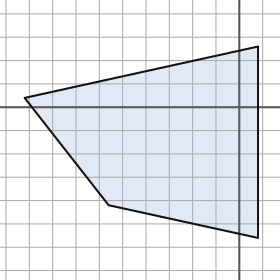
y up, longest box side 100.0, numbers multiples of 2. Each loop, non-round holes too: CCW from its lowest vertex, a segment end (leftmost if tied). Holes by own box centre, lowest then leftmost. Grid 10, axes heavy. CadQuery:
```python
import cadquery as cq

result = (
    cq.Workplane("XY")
    .moveTo(8.0, -56.0)
    .lineTo(8.0, 26.0)
    .lineTo(-92.0, 4.0)
    .lineTo(-56.0, -42.0)
    .close()
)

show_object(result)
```